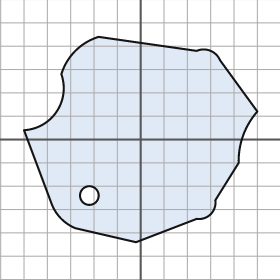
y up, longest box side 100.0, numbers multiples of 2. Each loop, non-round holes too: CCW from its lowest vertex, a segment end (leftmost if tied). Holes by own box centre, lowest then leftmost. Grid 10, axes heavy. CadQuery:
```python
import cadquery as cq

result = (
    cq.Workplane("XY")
    .moveTo(-2.0, -44.0)
    .lineTo(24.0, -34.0)
    .threePointArc((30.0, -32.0), (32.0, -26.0))
    .lineTo(42.0, -10.0)
    .threePointArc((44.0, 2.0), (50.0, 12.0))
    .lineTo(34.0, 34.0)
    .threePointArc((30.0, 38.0), (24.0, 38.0))
    .lineTo(-18.0, 44.0)
    .threePointArc((-28.0, 38.0), (-34.0, 28.0))
    .threePointArc((-36.0, 12.0), (-50.0, 4.0))
    .lineTo(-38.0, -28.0)
    .threePointArc((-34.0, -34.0), (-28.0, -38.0))
    .close()
    .moveTo(-22.0, -24.0)
    .circle(4.0)
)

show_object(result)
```